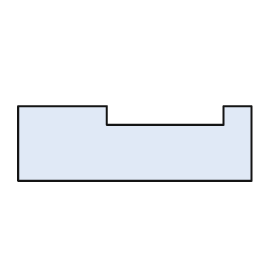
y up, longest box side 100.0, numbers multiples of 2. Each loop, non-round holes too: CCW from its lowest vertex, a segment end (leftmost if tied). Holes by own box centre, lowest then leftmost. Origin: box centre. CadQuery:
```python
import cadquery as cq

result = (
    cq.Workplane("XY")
    .moveTo(-50.0, -16.0)
    .lineTo(50.0, -16.0)
    .lineTo(50.0, 16.0)
    .lineTo(38.0, 16.0)
    .lineTo(38.0, 8.0)
    .lineTo(-12.0, 8.0)
    .lineTo(-12.0, 16.0)
    .lineTo(-50.0, 16.0)
    .close()
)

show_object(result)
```